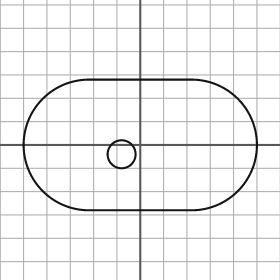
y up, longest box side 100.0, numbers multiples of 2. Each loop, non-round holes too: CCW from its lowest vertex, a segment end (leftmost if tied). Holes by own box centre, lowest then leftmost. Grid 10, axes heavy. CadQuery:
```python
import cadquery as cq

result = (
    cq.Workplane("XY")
    .moveTo(-22.0, -28.0)
    .lineTo(22.0, -28.0)
    .threePointArc((50.0, 0.0), (22.0, 28.0))
    .lineTo(-22.0, 28.0)
    .threePointArc((-50.0, 0.0), (-22.0, -28.0))
    .close()
    .moveTo(-8.0, -4.0)
    .circle(6.0)
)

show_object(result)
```